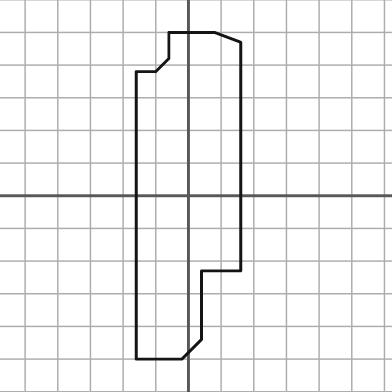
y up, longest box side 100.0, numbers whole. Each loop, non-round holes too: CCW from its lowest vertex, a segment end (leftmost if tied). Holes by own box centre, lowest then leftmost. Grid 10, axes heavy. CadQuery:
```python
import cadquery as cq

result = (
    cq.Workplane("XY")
    .moveTo(-16.0, -50.0)
    .lineTo(-2.0, -50.0)
    .lineTo(4.0, -44.0)
    .lineTo(4.0, -23.0)
    .lineTo(16.0, -23.0)
    .lineTo(16.0, 47.0)
    .lineTo(8.0, 50.0)
    .lineTo(-6.0, 50.0)
    .lineTo(-6.0, 42.0)
    .lineTo(-10.0, 38.0)
    .lineTo(-16.0, 38.0)
    .close()
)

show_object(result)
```